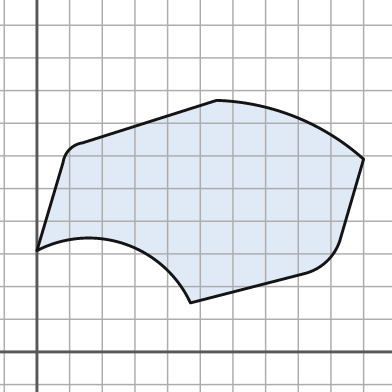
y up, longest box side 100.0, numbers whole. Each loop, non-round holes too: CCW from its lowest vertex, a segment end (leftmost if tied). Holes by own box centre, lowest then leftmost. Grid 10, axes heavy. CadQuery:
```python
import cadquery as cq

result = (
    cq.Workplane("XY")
    .moveTo(47.0, 15.0)
    .lineTo(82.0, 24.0)
    .threePointArc((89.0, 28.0), (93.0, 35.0))
    .lineTo(100.0, 59.0)
    .threePointArc((79.0, 72.0), (55.0, 77.0))
    .lineTo(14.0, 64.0)
    .threePointArc((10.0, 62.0), (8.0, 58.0))
    .lineTo(0.0, 31.0)
    .threePointArc((27.0, 33.0), (47.0, 15.0))
    .close()
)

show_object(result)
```